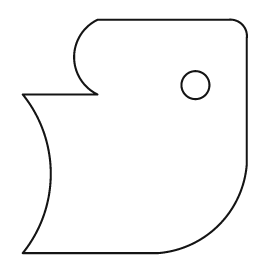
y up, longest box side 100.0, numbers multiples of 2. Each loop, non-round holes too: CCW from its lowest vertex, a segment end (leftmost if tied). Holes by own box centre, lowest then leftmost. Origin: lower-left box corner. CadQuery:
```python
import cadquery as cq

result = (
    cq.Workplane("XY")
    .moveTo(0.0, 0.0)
    .lineTo(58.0, 0.0)
    .threePointArc((84.0, 12.0), (96.0, 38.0))
    .lineTo(96.0, 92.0)
    .threePointArc((94.0, 98.0), (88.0, 100.0))
    .lineTo(32.0, 100.0)
    .threePointArc((22.0, 84.0), (32.0, 68.0))
    .lineTo(0.0, 68.0)
    .threePointArc((12.0, 34.0), (0.0, 0.0))
    .close()
    .moveTo(74.0, 72.0)
    .circle(6.0)
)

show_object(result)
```